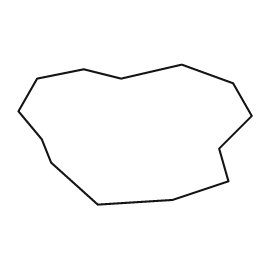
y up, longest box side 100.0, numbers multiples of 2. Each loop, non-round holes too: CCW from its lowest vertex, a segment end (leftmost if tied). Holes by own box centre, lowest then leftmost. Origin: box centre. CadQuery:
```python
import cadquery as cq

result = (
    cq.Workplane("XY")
    .moveTo(-16.0, -30.0)
    .lineTo(16.0, -28.0)
    .lineTo(40.0, -20.0)
    .lineTo(36.0, -6.0)
    .lineTo(50.0, 8.0)
    .lineTo(42.0, 22.0)
    .lineTo(20.0, 30.0)
    .lineTo(-6.0, 24.0)
    .lineTo(-22.0, 28.0)
    .lineTo(-42.0, 24.0)
    .lineTo(-50.0, 10.0)
    .lineTo(-40.0, -2.0)
    .lineTo(-36.0, -12.0)
    .close()
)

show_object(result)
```